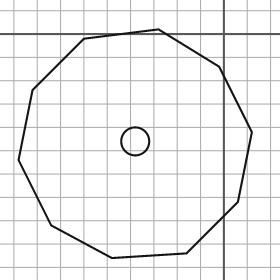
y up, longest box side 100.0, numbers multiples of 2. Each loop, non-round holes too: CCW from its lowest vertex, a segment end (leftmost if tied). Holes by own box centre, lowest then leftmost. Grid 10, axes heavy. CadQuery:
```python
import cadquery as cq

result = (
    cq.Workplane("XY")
    .moveTo(-48.0, -96.0)
    .lineTo(-16.0, -94.0)
    .lineTo(6.0, -72.0)
    .lineTo(12.0, -42.0)
    .lineTo(-2.0, -14.0)
    .lineTo(-28.0, 2.0)
    .lineTo(-60.0, -2.0)
    .lineTo(-82.0, -24.0)
    .lineTo(-88.0, -54.0)
    .lineTo(-74.0, -82.0)
    .close()
    .moveTo(-38.0, -46.0)
    .circle(6.0)
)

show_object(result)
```